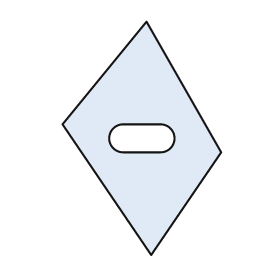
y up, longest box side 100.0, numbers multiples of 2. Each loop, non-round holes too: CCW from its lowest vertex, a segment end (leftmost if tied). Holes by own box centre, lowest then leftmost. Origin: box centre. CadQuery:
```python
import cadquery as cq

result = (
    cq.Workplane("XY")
    .moveTo(4.0, -50.0)
    .lineTo(34.0, -6.0)
    .lineTo(2.0, 50.0)
    .lineTo(-34.0, 6.0)
    .close()
    .moveTo(-8.0, -6.0)
    .lineTo(8.0, -6.0)
    .threePointArc((14.0, 0.0), (8.0, 6.0))
    .lineTo(-8.0, 6.0)
    .threePointArc((-14.0, 0.0), (-8.0, -6.0))
    .close()
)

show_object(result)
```